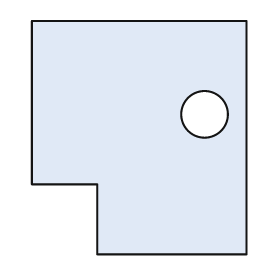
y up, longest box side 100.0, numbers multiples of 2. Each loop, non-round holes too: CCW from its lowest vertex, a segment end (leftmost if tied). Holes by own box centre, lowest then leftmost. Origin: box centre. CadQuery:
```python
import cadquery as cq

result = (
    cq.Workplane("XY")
    .moveTo(-18.0, -50.0)
    .lineTo(46.0, -50.0)
    .lineTo(46.0, 50.0)
    .lineTo(-46.0, 50.0)
    .lineTo(-46.0, -20.0)
    .lineTo(-18.0, -20.0)
    .close()
    .moveTo(28.0, 10.0)
    .circle(10.0)
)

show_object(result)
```